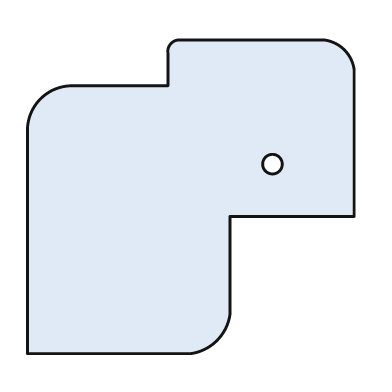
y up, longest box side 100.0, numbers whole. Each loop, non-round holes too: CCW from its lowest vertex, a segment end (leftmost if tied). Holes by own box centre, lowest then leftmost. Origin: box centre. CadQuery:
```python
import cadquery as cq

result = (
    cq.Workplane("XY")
    .moveTo(-50.0, -48.0)
    .lineTo(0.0, -48.0)
    .threePointArc((8.0, -44.0), (12.0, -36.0))
    .lineTo(12.0, -6.0)
    .lineTo(50.0, -6.0)
    .lineTo(50.0, 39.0)
    .threePointArc((47.0, 45.0), (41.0, 48.0))
    .lineTo(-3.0, 48.0)
    .threePointArc((-6.0, 47.0), (-7.0, 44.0))
    .lineTo(-7.0, 34.0)
    .lineTo(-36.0, 34.0)
    .threePointArc((-46.0, 30.0), (-50.0, 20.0))
    .close()
    .moveTo(25.0, 10.0)
    .circle(3.0)
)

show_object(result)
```